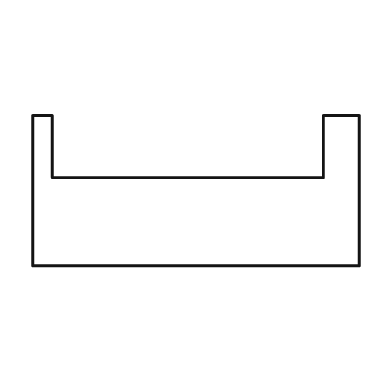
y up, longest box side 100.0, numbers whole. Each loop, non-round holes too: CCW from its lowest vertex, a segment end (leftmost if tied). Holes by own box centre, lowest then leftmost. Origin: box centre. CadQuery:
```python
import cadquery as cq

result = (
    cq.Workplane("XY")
    .moveTo(-50.0, -23.0)
    .lineTo(50.0, -23.0)
    .lineTo(50.0, 23.0)
    .lineTo(39.0, 23.0)
    .lineTo(39.0, 4.0)
    .lineTo(-44.0, 4.0)
    .lineTo(-44.0, 23.0)
    .lineTo(-50.0, 23.0)
    .close()
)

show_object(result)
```